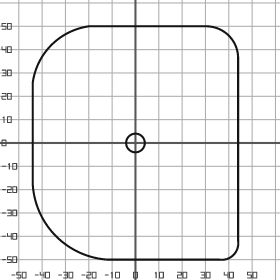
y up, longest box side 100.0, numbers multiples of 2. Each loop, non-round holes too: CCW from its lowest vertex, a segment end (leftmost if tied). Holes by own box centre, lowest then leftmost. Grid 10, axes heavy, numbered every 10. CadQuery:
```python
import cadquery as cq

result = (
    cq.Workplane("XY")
    .moveTo(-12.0, -50.0)
    .lineTo(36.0, -50.0)
    .threePointArc((42.0, -48.0), (44.0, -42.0))
    .lineTo(44.0, 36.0)
    .threePointArc((40.0, 46.0), (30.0, 50.0))
    .lineTo(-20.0, 50.0)
    .threePointArc((-36.0, 42.0), (-44.0, 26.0))
    .lineTo(-44.0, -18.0)
    .threePointArc((-34.0, -40.0), (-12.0, -50.0))
    .close()
    .moveTo(0.0, 0.0)
    .circle(4.0)
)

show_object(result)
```